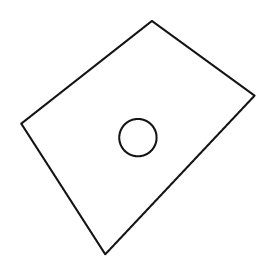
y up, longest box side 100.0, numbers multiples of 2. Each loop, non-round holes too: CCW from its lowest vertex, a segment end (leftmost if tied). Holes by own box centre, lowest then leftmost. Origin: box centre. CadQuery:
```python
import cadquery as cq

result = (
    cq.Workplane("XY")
    .moveTo(-14.0, -50.0)
    .lineTo(50.0, 18.0)
    .lineTo(6.0, 50.0)
    .lineTo(-50.0, 6.0)
    .close()
    .moveTo(0.0, 0.0)
    .circle(8.0)
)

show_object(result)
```